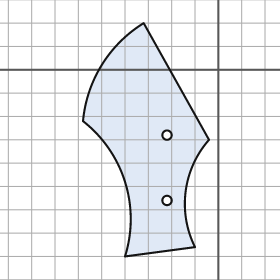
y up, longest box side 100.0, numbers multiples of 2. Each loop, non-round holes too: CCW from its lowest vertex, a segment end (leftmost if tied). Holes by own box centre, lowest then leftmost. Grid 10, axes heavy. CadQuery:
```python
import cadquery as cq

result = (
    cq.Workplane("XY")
    .moveTo(-40.0, -80.0)
    .lineTo(-10.0, -76.0)
    .threePointArc((-14.0, -52.0), (-4.0, -30.0))
    .lineTo(-32.0, 20.0)
    .threePointArc((-50.0, 2.0), (-58.0, -22.0))
    .threePointArc((-40.0, -48.0), (-40.0, -80.0))
    .close()
    .moveTo(-22.0, -56.0)
    .circle(2.0)
    .moveTo(-22.0, -28.0)
    .circle(2.0)
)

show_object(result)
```